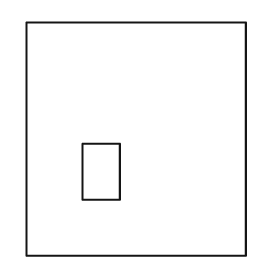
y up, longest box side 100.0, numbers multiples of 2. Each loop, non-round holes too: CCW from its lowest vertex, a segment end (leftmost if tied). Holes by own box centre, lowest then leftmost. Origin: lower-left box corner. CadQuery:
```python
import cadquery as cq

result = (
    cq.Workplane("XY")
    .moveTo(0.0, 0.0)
    .lineTo(94.0, 0.0)
    .lineTo(94.0, 100.0)
    .lineTo(0.0, 100.0)
    .close()
    .moveTo(24.0, 24.0)
    .lineTo(40.0, 24.0)
    .lineTo(40.0, 48.0)
    .lineTo(24.0, 48.0)
    .close()
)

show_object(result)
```